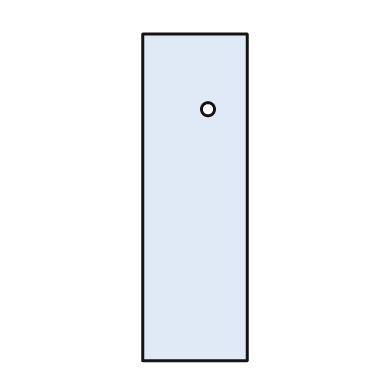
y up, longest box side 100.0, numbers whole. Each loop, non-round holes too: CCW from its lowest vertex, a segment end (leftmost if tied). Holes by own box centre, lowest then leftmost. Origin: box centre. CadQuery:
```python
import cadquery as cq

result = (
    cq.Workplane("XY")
    .moveTo(-16.0, -50.0)
    .lineTo(16.0, -50.0)
    .lineTo(16.0, 50.0)
    .lineTo(-16.0, 50.0)
    .close()
    .moveTo(4.0, 27.0)
    .circle(2.0)
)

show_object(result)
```